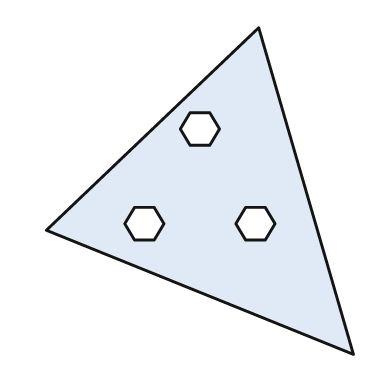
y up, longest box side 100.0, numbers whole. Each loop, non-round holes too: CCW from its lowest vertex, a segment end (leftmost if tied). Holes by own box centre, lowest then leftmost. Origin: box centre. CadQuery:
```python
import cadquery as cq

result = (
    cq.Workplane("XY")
    .moveTo(47.0, -50.0)
    .lineTo(18.0, 50.0)
    .lineTo(-47.0, -12.0)
    .close()
    .moveTo(-20.0, -15.0)
    .lineTo(-14.0, -15.0)
    .lineTo(-11.0, -10.0)
    .lineTo(-14.0, -5.0)
    .lineTo(-20.0, -5.0)
    .lineTo(-23.0, -10.0)
    .close()
    .moveTo(14.0, -15.0)
    .lineTo(20.0, -15.0)
    .lineTo(23.0, -10.0)
    .lineTo(20.0, -5.0)
    .lineTo(14.0, -5.0)
    .lineTo(11.0, -10.0)
    .close()
    .moveTo(-3.0, 14.0)
    .lineTo(3.0, 14.0)
    .lineTo(6.0, 19.0)
    .lineTo(3.0, 24.0)
    .lineTo(-3.0, 24.0)
    .lineTo(-6.0, 19.0)
    .close()
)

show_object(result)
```